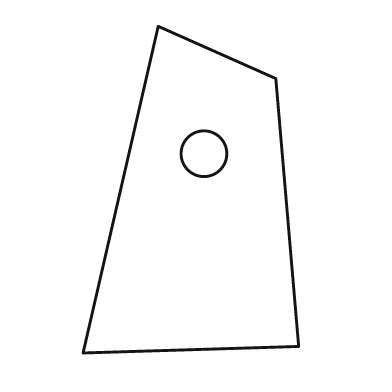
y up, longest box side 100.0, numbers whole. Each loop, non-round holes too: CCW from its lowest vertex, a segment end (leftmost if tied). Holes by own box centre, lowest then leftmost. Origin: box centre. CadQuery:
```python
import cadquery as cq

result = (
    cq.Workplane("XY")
    .moveTo(-33.0, -50.0)
    .lineTo(33.0, -48.0)
    .lineTo(26.0, 34.0)
    .lineTo(-10.0, 50.0)
    .close()
    .moveTo(4.0, 11.0)
    .circle(7.0)
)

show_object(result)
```